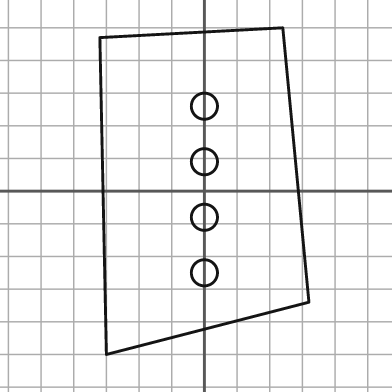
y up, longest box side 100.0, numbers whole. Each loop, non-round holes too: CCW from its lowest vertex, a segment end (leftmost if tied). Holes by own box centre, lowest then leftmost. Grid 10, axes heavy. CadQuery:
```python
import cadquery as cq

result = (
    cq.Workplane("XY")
    .moveTo(-30.0, -50.0)
    .lineTo(32.0, -34.0)
    .lineTo(24.0, 50.0)
    .lineTo(-32.0, 47.0)
    .close()
    .moveTo(0.0, -25.0)
    .circle(4.0)
    .moveTo(0.0, -8.0)
    .circle(4.0)
    .moveTo(0.0, 9.0)
    .circle(4.0)
    .moveTo(0.0, 26.0)
    .circle(4.0)
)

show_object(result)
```